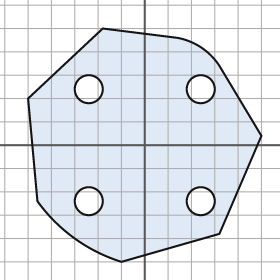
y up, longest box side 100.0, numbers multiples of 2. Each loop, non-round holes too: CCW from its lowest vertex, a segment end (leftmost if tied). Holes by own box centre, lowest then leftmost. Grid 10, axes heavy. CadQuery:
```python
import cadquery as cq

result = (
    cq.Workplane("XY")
    .moveTo(-10.0, -50.0)
    .lineTo(32.0, -38.0)
    .lineTo(50.0, 4.0)
    .lineTo(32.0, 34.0)
    .threePointArc((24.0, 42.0), (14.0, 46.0))
    .lineTo(-18.0, 50.0)
    .lineTo(-50.0, 20.0)
    .lineTo(-46.0, -24.0)
    .threePointArc((-30.0, -40.0), (-10.0, -50.0))
    .close()
    .moveTo(-24.0, -24.0)
    .circle(6.0)
    .moveTo(24.0, -24.0)
    .circle(6.0)
    .moveTo(-24.0, 24.0)
    .circle(6.0)
    .moveTo(24.0, 24.0)
    .circle(6.0)
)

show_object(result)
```